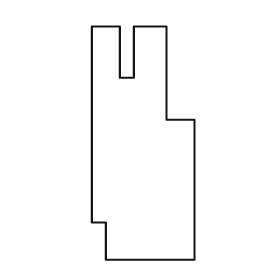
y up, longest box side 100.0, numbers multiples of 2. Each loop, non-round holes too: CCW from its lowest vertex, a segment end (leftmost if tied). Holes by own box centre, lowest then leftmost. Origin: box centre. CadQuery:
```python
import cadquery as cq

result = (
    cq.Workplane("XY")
    .moveTo(-16.0, -50.0)
    .lineTo(22.0, -50.0)
    .lineTo(22.0, 10.0)
    .lineTo(10.0, 10.0)
    .lineTo(10.0, 50.0)
    .lineTo(-4.0, 50.0)
    .lineTo(-4.0, 28.0)
    .lineTo(-10.0, 28.0)
    .lineTo(-10.0, 50.0)
    .lineTo(-22.0, 50.0)
    .lineTo(-22.0, -34.0)
    .lineTo(-16.0, -34.0)
    .close()
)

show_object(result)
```